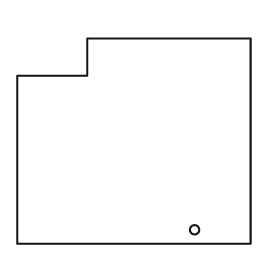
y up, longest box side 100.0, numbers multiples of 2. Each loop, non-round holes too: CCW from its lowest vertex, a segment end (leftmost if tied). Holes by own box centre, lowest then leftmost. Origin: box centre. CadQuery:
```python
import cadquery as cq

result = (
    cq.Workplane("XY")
    .moveTo(-50.0, -44.0)
    .lineTo(50.0, -44.0)
    .lineTo(50.0, 44.0)
    .lineTo(-20.0, 44.0)
    .lineTo(-20.0, 28.0)
    .lineTo(-50.0, 28.0)
    .close()
    .moveTo(26.0, -38.0)
    .circle(2.0)
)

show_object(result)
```